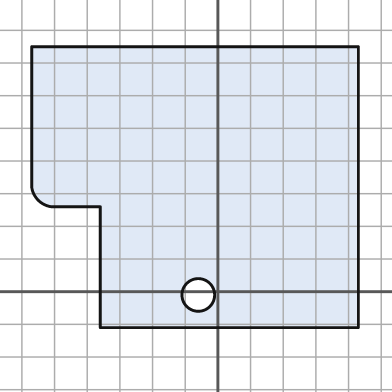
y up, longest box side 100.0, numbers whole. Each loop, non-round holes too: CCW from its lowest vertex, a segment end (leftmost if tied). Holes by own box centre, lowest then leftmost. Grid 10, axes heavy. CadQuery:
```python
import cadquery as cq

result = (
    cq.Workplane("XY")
    .moveTo(-36.0, -11.0)
    .lineTo(43.0, -11.0)
    .lineTo(43.0, 75.0)
    .lineTo(-57.0, 75.0)
    .lineTo(-57.0, 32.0)
    .threePointArc((-55.0, 28.0), (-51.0, 26.0))
    .lineTo(-36.0, 26.0)
    .close()
    .moveTo(-6.0, -1.0)
    .circle(5.0)
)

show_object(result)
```